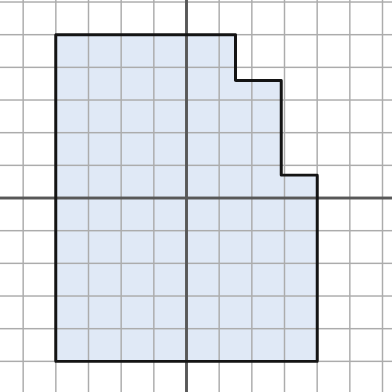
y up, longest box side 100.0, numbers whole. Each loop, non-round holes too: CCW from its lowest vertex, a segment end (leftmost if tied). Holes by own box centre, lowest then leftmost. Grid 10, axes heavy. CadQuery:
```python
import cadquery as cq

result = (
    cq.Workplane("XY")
    .moveTo(-40.0, -50.0)
    .lineTo(40.0, -50.0)
    .lineTo(40.0, 7.0)
    .lineTo(29.0, 7.0)
    .lineTo(29.0, 36.0)
    .lineTo(15.0, 36.0)
    .lineTo(15.0, 50.0)
    .lineTo(-40.0, 50.0)
    .close()
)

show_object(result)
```